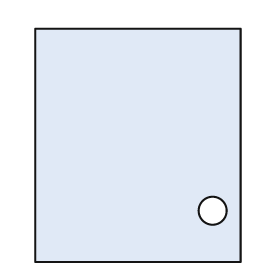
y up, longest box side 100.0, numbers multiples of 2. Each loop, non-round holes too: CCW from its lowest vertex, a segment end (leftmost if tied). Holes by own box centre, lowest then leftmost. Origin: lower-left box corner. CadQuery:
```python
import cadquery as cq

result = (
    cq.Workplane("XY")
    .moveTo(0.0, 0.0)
    .lineTo(88.0, 0.0)
    .lineTo(88.0, 100.0)
    .lineTo(0.0, 100.0)
    .close()
    .moveTo(76.0, 22.0)
    .circle(6.0)
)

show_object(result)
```